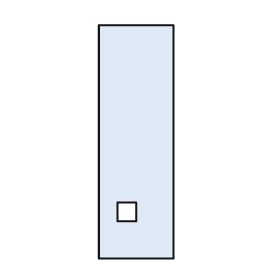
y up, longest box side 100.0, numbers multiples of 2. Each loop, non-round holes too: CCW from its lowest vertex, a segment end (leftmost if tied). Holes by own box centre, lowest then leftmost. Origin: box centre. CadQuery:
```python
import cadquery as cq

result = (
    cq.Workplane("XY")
    .moveTo(-16.0, -50.0)
    .lineTo(16.0, -50.0)
    .lineTo(16.0, 50.0)
    .lineTo(-16.0, 50.0)
    .close()
    .moveTo(-8.0, -34.0)
    .lineTo(0.0, -34.0)
    .lineTo(0.0, -26.0)
    .lineTo(-8.0, -26.0)
    .close()
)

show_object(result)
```